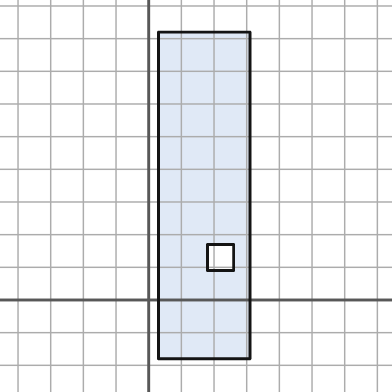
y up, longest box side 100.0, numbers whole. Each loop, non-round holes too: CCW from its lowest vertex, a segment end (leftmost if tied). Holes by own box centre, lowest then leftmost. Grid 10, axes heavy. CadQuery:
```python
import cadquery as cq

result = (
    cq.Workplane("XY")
    .moveTo(3.0, -18.0)
    .lineTo(31.0, -18.0)
    .lineTo(31.0, 82.0)
    .lineTo(3.0, 82.0)
    .close()
    .moveTo(18.0, 9.0)
    .lineTo(26.0, 9.0)
    .lineTo(26.0, 17.0)
    .lineTo(18.0, 17.0)
    .close()
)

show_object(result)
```